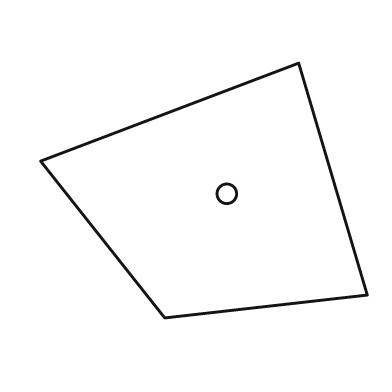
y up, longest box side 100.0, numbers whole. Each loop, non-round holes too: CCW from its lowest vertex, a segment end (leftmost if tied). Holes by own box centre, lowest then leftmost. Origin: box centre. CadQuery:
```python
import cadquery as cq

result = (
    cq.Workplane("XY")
    .moveTo(-12.0, -39.0)
    .lineTo(50.0, -32.0)
    .lineTo(29.0, 39.0)
    .lineTo(-50.0, 9.0)
    .close()
    .moveTo(7.0, -1.0)
    .circle(3.0)
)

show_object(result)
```